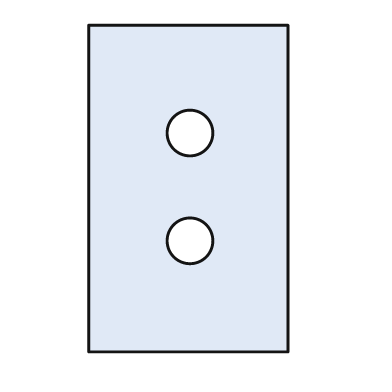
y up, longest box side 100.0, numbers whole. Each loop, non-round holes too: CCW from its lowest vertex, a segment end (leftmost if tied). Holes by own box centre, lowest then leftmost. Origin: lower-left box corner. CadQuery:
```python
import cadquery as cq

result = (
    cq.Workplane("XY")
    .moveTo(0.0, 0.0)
    .lineTo(61.0, 0.0)
    .lineTo(61.0, 100.0)
    .lineTo(0.0, 100.0)
    .close()
    .moveTo(31.0, 34.0)
    .circle(7.0)
    .moveTo(31.0, 67.0)
    .circle(7.0)
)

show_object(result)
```